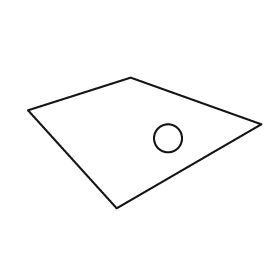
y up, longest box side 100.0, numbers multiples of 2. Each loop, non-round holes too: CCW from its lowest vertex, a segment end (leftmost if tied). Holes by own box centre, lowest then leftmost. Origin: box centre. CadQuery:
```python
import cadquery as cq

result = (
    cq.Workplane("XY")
    .moveTo(-12.0, -28.0)
    .lineTo(50.0, 8.0)
    .lineTo(-6.0, 28.0)
    .lineTo(-50.0, 14.0)
    .close()
    .moveTo(10.0, 2.0)
    .circle(6.0)
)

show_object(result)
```